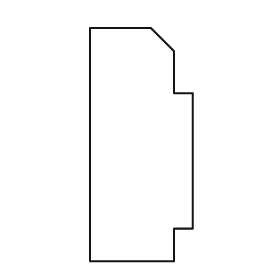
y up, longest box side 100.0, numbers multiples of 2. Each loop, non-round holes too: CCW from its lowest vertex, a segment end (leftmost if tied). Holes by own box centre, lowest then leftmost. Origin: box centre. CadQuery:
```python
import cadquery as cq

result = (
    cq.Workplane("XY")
    .moveTo(-22.0, -50.0)
    .lineTo(14.0, -50.0)
    .lineTo(14.0, -36.0)
    .lineTo(22.0, -36.0)
    .lineTo(22.0, 22.0)
    .lineTo(14.0, 22.0)
    .lineTo(14.0, 40.0)
    .lineTo(4.0, 50.0)
    .lineTo(-22.0, 50.0)
    .close()
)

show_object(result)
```